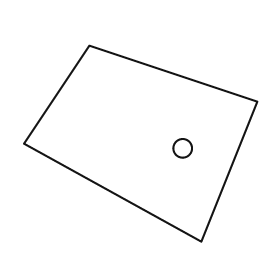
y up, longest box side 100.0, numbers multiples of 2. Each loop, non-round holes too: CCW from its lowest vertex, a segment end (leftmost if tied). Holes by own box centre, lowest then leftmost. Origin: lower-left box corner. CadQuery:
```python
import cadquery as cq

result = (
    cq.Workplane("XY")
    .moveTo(76.0, 0.0)
    .lineTo(100.0, 60.0)
    .lineTo(28.0, 84.0)
    .lineTo(0.0, 42.0)
    .close()
    .moveTo(68.0, 40.0)
    .circle(4.0)
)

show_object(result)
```